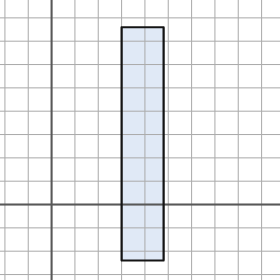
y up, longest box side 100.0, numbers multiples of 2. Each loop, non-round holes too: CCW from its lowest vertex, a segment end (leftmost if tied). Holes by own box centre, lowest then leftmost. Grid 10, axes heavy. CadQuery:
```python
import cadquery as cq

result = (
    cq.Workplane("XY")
    .moveTo(30.0, -24.0)
    .lineTo(48.0, -24.0)
    .lineTo(48.0, 76.0)
    .lineTo(30.0, 76.0)
    .close()
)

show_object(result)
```